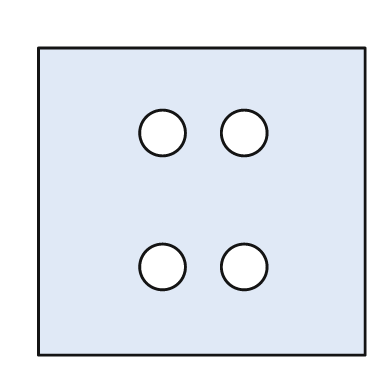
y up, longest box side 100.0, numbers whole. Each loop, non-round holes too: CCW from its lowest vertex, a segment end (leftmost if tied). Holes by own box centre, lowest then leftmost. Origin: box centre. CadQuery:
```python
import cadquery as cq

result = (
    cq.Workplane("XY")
    .moveTo(-50.0, -47.0)
    .lineTo(50.0, -47.0)
    .lineTo(50.0, 47.0)
    .lineTo(-50.0, 47.0)
    .close()
    .moveTo(-12.0, -20.0)
    .circle(7.0)
    .moveTo(13.0, -20.0)
    .circle(7.0)
    .moveTo(-12.0, 21.0)
    .circle(7.0)
    .moveTo(13.0, 21.0)
    .circle(7.0)
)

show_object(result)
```